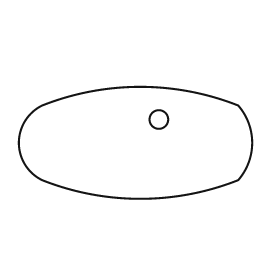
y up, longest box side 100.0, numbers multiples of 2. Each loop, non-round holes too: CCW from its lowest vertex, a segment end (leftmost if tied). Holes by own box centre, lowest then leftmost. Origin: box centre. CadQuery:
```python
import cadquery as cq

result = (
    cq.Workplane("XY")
    .moveTo(-40.0, -16.0)
    .threePointArc((2.0, -24.0), (44.0, -16.0))
    .threePointArc((50.0, 0.0), (44.0, 16.0))
    .threePointArc((2.0, 24.0), (-40.0, 16.0))
    .threePointArc((-50.0, 0.0), (-40.0, -16.0))
    .close()
    .moveTo(10.0, 10.0)
    .circle(4.0)
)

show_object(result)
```